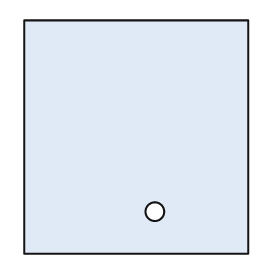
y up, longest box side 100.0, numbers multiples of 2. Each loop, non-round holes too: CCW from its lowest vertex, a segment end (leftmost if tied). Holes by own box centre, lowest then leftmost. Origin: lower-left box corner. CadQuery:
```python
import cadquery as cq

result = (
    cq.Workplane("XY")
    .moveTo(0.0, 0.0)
    .lineTo(96.0, 0.0)
    .lineTo(96.0, 100.0)
    .lineTo(0.0, 100.0)
    .close()
    .moveTo(56.0, 18.0)
    .circle(4.0)
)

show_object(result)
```